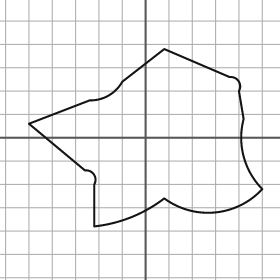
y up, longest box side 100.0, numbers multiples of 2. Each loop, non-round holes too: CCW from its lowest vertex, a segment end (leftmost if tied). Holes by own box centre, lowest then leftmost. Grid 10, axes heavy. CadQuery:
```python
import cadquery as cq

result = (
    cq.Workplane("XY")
    .moveTo(-22.0, -38.0)
    .threePointArc((-6.0, -34.0), (8.0, -26.0))
    .threePointArc((30.0, -32.0), (50.0, -22.0))
    .threePointArc((42.0, -8.0), (42.0, 8.0))
    .lineTo(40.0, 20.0)
    .threePointArc((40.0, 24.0), (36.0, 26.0))
    .lineTo(8.0, 38.0)
    .lineTo(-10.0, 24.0)
    .threePointArc((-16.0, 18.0), (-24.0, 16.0))
    .lineTo(-50.0, 6.0)
    .lineTo(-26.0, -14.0)
    .threePointArc((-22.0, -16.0), (-22.0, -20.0))
    .close()
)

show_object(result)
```